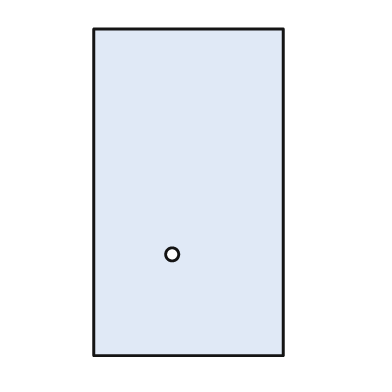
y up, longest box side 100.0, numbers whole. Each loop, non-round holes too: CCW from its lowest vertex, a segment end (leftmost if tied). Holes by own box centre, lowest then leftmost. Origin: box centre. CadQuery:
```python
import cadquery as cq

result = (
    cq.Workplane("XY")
    .moveTo(-29.0, -50.0)
    .lineTo(29.0, -50.0)
    .lineTo(29.0, 50.0)
    .lineTo(-29.0, 50.0)
    .close()
    .moveTo(-5.0, -19.0)
    .circle(2.0)
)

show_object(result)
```